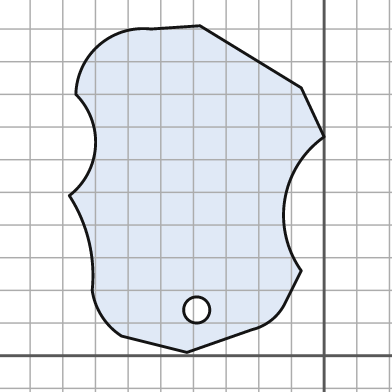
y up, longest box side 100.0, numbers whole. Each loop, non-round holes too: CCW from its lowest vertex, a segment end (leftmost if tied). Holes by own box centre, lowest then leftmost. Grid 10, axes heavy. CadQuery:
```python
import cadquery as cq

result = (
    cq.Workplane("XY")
    .moveTo(-42.0, 1.0)
    .lineTo(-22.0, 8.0)
    .threePointArc((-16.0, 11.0), (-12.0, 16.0))
    .lineTo(-7.0, 26.0)
    .threePointArc((-12.0, 48.0), (0.0, 67.0))
    .lineTo(-7.0, 82.0)
    .lineTo(-38.0, 101.0)
    .lineTo(-53.0, 100.0)
    .threePointArc((-69.0, 95.0), (-76.0, 80.0))
    .threePointArc((-70.0, 64.0), (-78.0, 49.0))
    .threePointArc((-72.0, 35.0), (-71.0, 20.0))
    .threePointArc((-68.0, 12.0), (-62.0, 6.0))
    .close()
    .moveTo(-39.0, 14.0)
    .circle(4.0)
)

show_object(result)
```